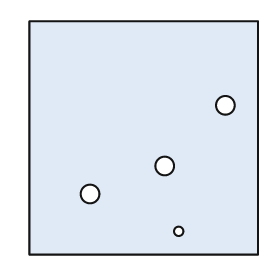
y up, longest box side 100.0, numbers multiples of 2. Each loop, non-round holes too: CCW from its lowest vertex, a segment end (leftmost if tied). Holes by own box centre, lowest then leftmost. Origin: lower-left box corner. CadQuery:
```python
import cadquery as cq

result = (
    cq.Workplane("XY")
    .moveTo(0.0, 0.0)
    .lineTo(98.0, 0.0)
    .lineTo(98.0, 100.0)
    .lineTo(0.0, 100.0)
    .close()
    .moveTo(64.0, 10.0)
    .circle(2.0)
    .moveTo(26.0, 26.0)
    .circle(4.0)
    .moveTo(58.0, 38.0)
    .circle(4.0)
    .moveTo(84.0, 64.0)
    .circle(4.0)
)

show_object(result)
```